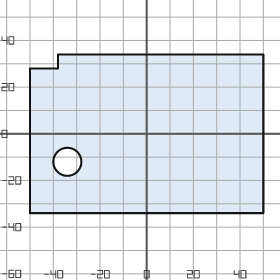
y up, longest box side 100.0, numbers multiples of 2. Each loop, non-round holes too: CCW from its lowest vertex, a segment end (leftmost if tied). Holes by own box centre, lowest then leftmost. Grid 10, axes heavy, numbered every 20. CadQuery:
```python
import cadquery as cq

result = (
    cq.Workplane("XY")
    .moveTo(-50.0, -34.0)
    .lineTo(50.0, -34.0)
    .lineTo(50.0, 34.0)
    .lineTo(-38.0, 34.0)
    .lineTo(-38.0, 28.0)
    .lineTo(-50.0, 28.0)
    .close()
    .moveTo(-34.0, -12.0)
    .circle(6.0)
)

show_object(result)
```